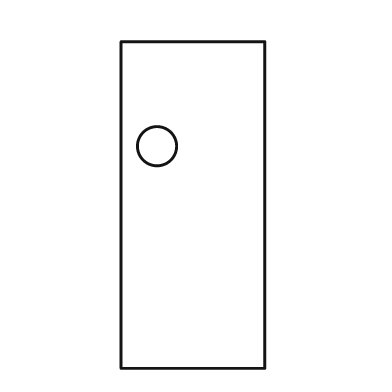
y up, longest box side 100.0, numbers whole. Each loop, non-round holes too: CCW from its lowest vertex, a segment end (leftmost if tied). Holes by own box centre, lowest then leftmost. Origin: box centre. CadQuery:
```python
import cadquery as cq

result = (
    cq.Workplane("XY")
    .moveTo(-22.0, -50.0)
    .lineTo(22.0, -50.0)
    .lineTo(22.0, 50.0)
    .lineTo(-22.0, 50.0)
    .close()
    .moveTo(-11.0, 18.0)
    .circle(6.0)
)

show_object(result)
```